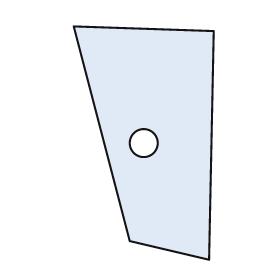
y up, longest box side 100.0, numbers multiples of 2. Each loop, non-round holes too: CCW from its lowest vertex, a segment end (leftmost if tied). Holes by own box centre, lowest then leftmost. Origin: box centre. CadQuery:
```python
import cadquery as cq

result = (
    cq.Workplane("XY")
    .moveTo(28.0, -50.0)
    .lineTo(30.0, 48.0)
    .lineTo(-30.0, 50.0)
    .lineTo(-6.0, -42.0)
    .close()
    .moveTo(0.0, 0.0)
    .circle(6.0)
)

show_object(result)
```